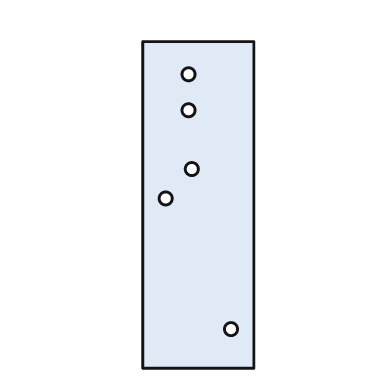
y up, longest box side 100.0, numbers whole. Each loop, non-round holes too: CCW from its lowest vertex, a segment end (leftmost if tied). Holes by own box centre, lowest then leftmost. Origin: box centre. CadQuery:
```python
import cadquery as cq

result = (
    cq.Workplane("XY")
    .moveTo(-17.0, -50.0)
    .lineTo(17.0, -50.0)
    .lineTo(17.0, 50.0)
    .lineTo(-17.0, 50.0)
    .close()
    .moveTo(10.0, -38.0)
    .circle(2.0)
    .moveTo(-10.0, 2.0)
    .circle(2.0)
    .moveTo(-2.0, 11.0)
    .circle(2.0)
    .moveTo(-3.0, 29.0)
    .circle(2.0)
    .moveTo(-3.0, 40.0)
    .circle(2.0)
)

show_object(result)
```